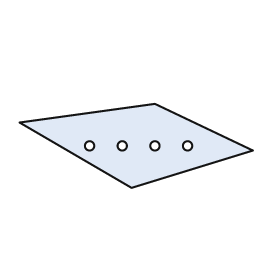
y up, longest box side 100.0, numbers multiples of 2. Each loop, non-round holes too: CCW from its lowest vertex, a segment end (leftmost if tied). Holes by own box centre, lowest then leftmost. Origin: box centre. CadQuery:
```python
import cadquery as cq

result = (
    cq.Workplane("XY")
    .moveTo(-2.0, -18.0)
    .lineTo(50.0, -2.0)
    .lineTo(8.0, 18.0)
    .lineTo(-50.0, 10.0)
    .close()
    .moveTo(-20.0, 0.0)
    .circle(2.0)
    .moveTo(-6.0, 0.0)
    .circle(2.0)
    .moveTo(8.0, 0.0)
    .circle(2.0)
    .moveTo(22.0, 0.0)
    .circle(2.0)
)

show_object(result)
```